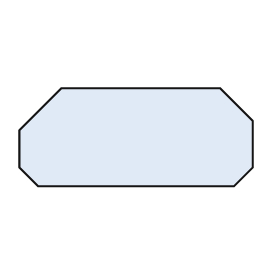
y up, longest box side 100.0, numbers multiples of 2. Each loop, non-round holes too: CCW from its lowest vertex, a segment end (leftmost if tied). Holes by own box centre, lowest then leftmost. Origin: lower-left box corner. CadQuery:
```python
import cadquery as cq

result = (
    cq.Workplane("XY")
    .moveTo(8.0, 0.0)
    .lineTo(92.0, 0.0)
    .lineTo(100.0, 8.0)
    .lineTo(100.0, 28.0)
    .lineTo(86.0, 42.0)
    .lineTo(18.0, 42.0)
    .lineTo(0.0, 24.0)
    .lineTo(0.0, 8.0)
    .close()
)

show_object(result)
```